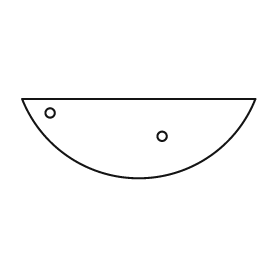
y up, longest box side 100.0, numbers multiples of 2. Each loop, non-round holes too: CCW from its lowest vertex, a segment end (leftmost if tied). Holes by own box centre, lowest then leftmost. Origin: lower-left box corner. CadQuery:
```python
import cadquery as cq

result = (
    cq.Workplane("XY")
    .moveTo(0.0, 34.0)
    .threePointArc((50.0, 0.0), (100.0, 34.0))
    .close()
    .moveTo(60.0, 18.0)
    .circle(2.0)
    .moveTo(12.0, 28.0)
    .circle(2.0)
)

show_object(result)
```